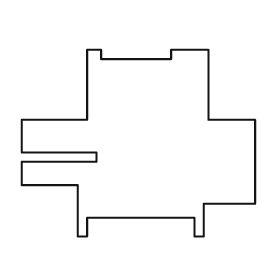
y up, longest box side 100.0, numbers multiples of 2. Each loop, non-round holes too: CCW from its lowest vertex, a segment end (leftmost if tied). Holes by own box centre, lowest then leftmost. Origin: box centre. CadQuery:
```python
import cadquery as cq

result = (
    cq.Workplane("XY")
    .moveTo(-26.0, -40.0)
    .lineTo(-22.0, -40.0)
    .lineTo(-22.0, -32.0)
    .lineTo(24.0, -32.0)
    .lineTo(24.0, -40.0)
    .lineTo(28.0, -40.0)
    .lineTo(28.0, -26.0)
    .lineTo(50.0, -26.0)
    .lineTo(50.0, 10.0)
    .lineTo(30.0, 10.0)
    .lineTo(30.0, 40.0)
    .lineTo(14.0, 40.0)
    .lineTo(14.0, 36.0)
    .lineTo(-16.0, 36.0)
    .lineTo(-16.0, 40.0)
    .lineTo(-22.0, 40.0)
    .lineTo(-22.0, 10.0)
    .lineTo(-50.0, 10.0)
    .lineTo(-50.0, -4.0)
    .lineTo(-18.0, -4.0)
    .lineTo(-18.0, -8.0)
    .lineTo(-50.0, -8.0)
    .lineTo(-50.0, -18.0)
    .lineTo(-26.0, -18.0)
    .close()
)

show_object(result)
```